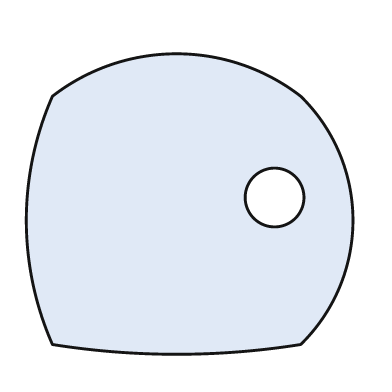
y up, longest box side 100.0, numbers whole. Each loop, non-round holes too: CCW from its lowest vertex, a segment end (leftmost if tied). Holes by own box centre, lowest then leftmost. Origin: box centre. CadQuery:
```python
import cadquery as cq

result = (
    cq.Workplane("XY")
    .moveTo(-42.0, -43.0)
    .threePointArc((-4.0, -46.0), (34.0, -43.0))
    .threePointArc((50.0, -5.0), (34.0, 33.0))
    .threePointArc((-4.0, 46.0), (-42.0, 33.0))
    .threePointArc((-50.0, -5.0), (-42.0, -43.0))
    .close()
    .moveTo(26.0, 2.0)
    .circle(9.0)
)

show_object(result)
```